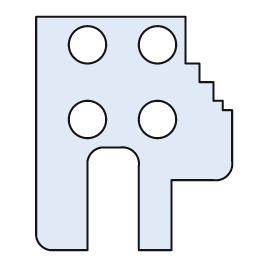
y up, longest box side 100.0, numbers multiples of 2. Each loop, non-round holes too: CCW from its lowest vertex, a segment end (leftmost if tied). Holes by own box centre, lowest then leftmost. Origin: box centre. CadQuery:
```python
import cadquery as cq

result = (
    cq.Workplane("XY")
    .moveTo(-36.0, -50.0)
    .lineTo(-20.0, -50.0)
    .lineTo(-20.0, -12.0)
    .threePointArc((-18.0, -8.0), (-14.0, -6.0))
    .lineTo(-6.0, -6.0)
    .threePointArc((0.0, -8.0), (2.0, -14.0))
    .lineTo(2.0, -50.0)
    .lineTo(16.0, -50.0)
    .lineTo(16.0, -20.0)
    .lineTo(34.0, -20.0)
    .threePointArc((40.0, -18.0), (42.0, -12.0))
    .lineTo(42.0, 10.0)
    .lineTo(38.0, 10.0)
    .lineTo(38.0, 14.0)
    .lineTo(34.0, 14.0)
    .lineTo(34.0, 22.0)
    .lineTo(28.0, 22.0)
    .lineTo(28.0, 30.0)
    .lineTo(22.0, 30.0)
    .lineTo(22.0, 50.0)
    .lineTo(-42.0, 50.0)
    .lineTo(-42.0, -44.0)
    .threePointArc((-40.0, -48.0), (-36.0, -50.0))
    .close()
    .moveTo(-20.0, 6.0)
    .circle(8.0)
    .moveTo(10.0, 6.0)
    .circle(8.0)
    .moveTo(-20.0, 38.0)
    .circle(8.0)
    .moveTo(10.0, 38.0)
    .circle(8.0)
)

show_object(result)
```